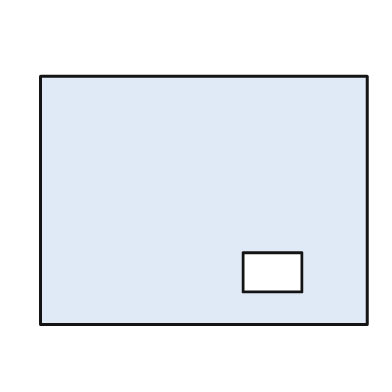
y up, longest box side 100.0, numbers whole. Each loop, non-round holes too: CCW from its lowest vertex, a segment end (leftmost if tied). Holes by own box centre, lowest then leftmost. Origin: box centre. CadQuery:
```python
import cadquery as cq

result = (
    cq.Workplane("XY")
    .moveTo(-50.0, -38.0)
    .lineTo(50.0, -38.0)
    .lineTo(50.0, 38.0)
    .lineTo(-50.0, 38.0)
    .close()
    .moveTo(12.0, -28.0)
    .lineTo(30.0, -28.0)
    .lineTo(30.0, -16.0)
    .lineTo(12.0, -16.0)
    .close()
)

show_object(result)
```